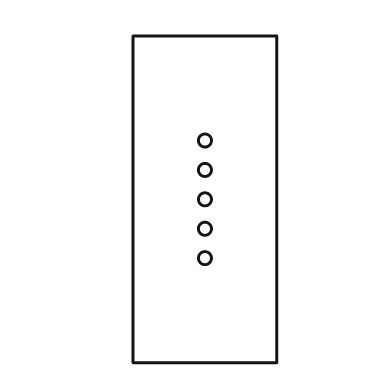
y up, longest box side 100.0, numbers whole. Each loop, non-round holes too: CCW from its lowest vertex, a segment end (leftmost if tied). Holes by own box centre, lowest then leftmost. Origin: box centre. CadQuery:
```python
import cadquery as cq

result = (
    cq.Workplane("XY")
    .moveTo(-22.0, -50.0)
    .lineTo(22.0, -50.0)
    .lineTo(22.0, 50.0)
    .lineTo(-22.0, 50.0)
    .close()
    .moveTo(0.0, -18.0)
    .circle(2.0)
    .moveTo(0.0, -9.0)
    .circle(2.0)
    .moveTo(0.0, 0.0)
    .circle(2.0)
    .moveTo(0.0, 9.0)
    .circle(2.0)
    .moveTo(0.0, 18.0)
    .circle(2.0)
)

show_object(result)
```